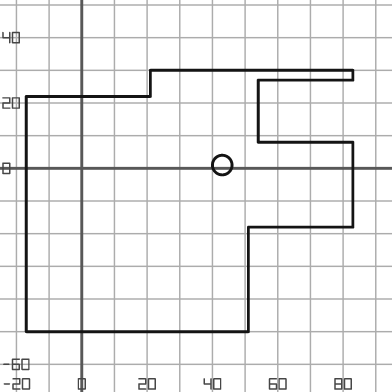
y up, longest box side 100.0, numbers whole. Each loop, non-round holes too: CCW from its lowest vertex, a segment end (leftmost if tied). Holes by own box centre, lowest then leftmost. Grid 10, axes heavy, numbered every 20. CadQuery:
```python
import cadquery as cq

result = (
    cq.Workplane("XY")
    .moveTo(-17.0, -50.0)
    .lineTo(51.0, -50.0)
    .lineTo(51.0, -18.0)
    .lineTo(83.0, -18.0)
    .lineTo(83.0, 8.0)
    .lineTo(54.0, 8.0)
    .lineTo(54.0, 27.0)
    .lineTo(83.0, 27.0)
    .lineTo(83.0, 30.0)
    .lineTo(21.0, 30.0)
    .lineTo(21.0, 22.0)
    .lineTo(-17.0, 22.0)
    .close()
    .moveTo(43.0, 1.0)
    .circle(3.0)
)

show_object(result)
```